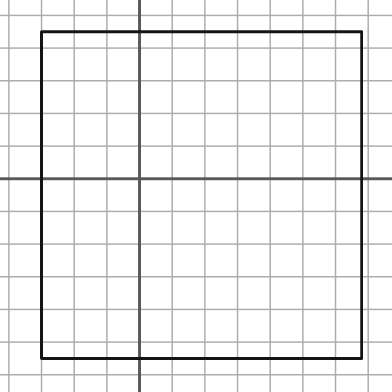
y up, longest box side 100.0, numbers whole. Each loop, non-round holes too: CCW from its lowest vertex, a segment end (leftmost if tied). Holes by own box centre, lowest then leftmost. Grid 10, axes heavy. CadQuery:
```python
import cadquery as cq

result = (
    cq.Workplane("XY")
    .moveTo(-30.0, -55.0)
    .lineTo(68.0, -55.0)
    .lineTo(68.0, 45.0)
    .lineTo(-30.0, 45.0)
    .close()
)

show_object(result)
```